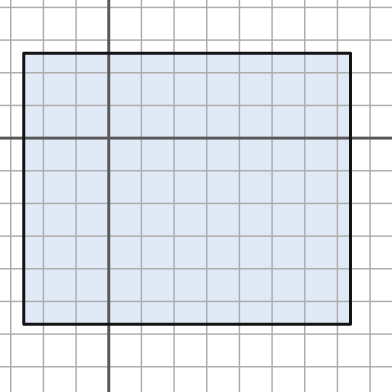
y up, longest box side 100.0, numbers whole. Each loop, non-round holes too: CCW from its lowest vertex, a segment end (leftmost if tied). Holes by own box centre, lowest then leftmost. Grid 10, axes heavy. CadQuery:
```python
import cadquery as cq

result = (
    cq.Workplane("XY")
    .moveTo(-26.0, -57.0)
    .lineTo(74.0, -57.0)
    .lineTo(74.0, 26.0)
    .lineTo(-26.0, 26.0)
    .close()
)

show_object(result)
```